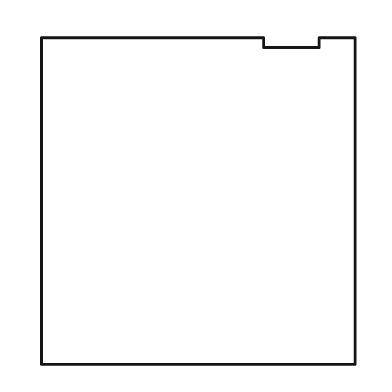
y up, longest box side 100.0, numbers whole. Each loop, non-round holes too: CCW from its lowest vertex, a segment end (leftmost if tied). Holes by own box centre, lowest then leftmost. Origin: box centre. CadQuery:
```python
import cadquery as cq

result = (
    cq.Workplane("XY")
    .moveTo(-48.0, -50.0)
    .lineTo(48.0, -50.0)
    .lineTo(48.0, 50.0)
    .lineTo(37.0, 50.0)
    .lineTo(37.0, 47.0)
    .lineTo(20.0, 47.0)
    .lineTo(20.0, 50.0)
    .lineTo(-48.0, 50.0)
    .close()
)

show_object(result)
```